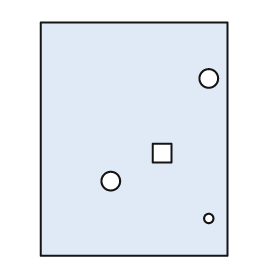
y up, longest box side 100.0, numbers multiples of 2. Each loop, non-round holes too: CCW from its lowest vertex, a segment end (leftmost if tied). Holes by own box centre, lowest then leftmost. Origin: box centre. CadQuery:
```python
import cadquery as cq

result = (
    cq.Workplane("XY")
    .moveTo(-40.0, -50.0)
    .lineTo(40.0, -50.0)
    .lineTo(40.0, 50.0)
    .lineTo(-40.0, 50.0)
    .close()
    .moveTo(32.0, -34.0)
    .circle(2.0)
    .moveTo(-10.0, -18.0)
    .circle(4.0)
    .moveTo(8.0, -10.0)
    .lineTo(16.0, -10.0)
    .lineTo(16.0, -2.0)
    .lineTo(8.0, -2.0)
    .close()
    .moveTo(32.0, 26.0)
    .circle(4.0)
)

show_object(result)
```